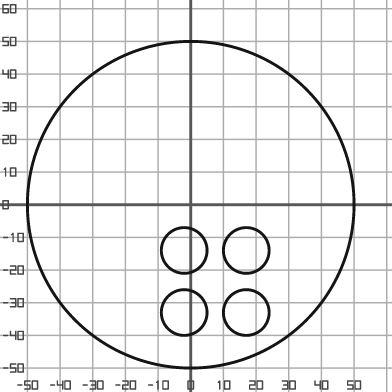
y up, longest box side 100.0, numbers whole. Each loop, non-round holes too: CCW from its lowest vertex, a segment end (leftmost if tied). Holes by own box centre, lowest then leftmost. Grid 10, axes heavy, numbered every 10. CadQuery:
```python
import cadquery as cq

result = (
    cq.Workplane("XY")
    .moveTo(0.0, 0.0)
    .circle(50.0)
    .moveTo(-2.0, -33.0)
    .circle(7.0)
    .moveTo(17.0, -33.0)
    .circle(7.0)
    .moveTo(-2.0, -14.0)
    .circle(7.0)
    .moveTo(17.0, -14.0)
    .circle(7.0)
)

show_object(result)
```